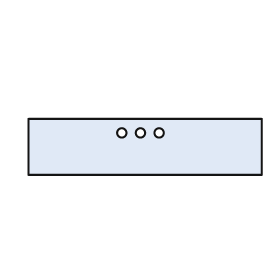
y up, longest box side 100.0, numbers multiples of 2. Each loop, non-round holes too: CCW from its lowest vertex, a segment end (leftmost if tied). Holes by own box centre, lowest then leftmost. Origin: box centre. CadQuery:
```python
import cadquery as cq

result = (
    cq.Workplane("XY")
    .moveTo(-50.0, -12.0)
    .lineTo(50.0, -12.0)
    .lineTo(50.0, 12.0)
    .lineTo(-50.0, 12.0)
    .close()
    .moveTo(-10.0, 6.0)
    .circle(2.0)
    .moveTo(-2.0, 6.0)
    .circle(2.0)
    .moveTo(6.0, 6.0)
    .circle(2.0)
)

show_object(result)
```